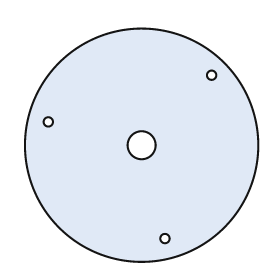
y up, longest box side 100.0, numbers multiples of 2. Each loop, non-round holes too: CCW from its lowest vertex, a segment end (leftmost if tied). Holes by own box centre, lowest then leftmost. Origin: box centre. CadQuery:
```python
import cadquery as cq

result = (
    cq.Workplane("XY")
    .moveTo(0.0, 0.0)
    .circle(50.0)
    .moveTo(10.0, -40.0)
    .circle(2.0)
    .moveTo(0.0, 0.0)
    .circle(6.0)
    .moveTo(-40.0, 10.0)
    .circle(2.0)
    .moveTo(30.0, 30.0)
    .circle(2.0)
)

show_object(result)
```